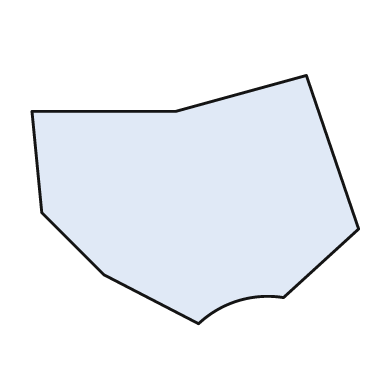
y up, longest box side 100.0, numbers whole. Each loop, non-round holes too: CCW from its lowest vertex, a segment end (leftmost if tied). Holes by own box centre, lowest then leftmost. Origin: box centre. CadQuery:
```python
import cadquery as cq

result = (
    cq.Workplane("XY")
    .moveTo(1.0, -38.0)
    .threePointArc((13.0, -31.0), (27.0, -30.0))
    .lineTo(50.0, -9.0)
    .lineTo(34.0, 38.0)
    .lineTo(-6.0, 27.0)
    .lineTo(-50.0, 27.0)
    .lineTo(-47.0, -4.0)
    .lineTo(-28.0, -23.0)
    .close()
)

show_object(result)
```